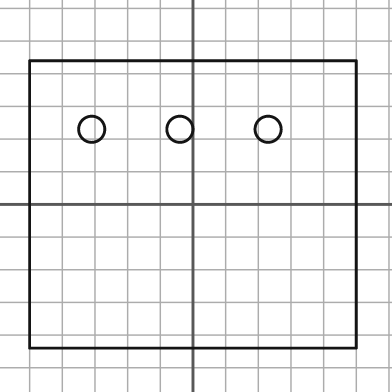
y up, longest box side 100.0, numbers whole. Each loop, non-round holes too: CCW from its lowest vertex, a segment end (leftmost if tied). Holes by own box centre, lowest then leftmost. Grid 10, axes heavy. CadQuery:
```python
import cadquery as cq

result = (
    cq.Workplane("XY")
    .moveTo(-50.0, -44.0)
    .lineTo(50.0, -44.0)
    .lineTo(50.0, 44.0)
    .lineTo(-50.0, 44.0)
    .close()
    .moveTo(-31.0, 23.0)
    .circle(4.0)
    .moveTo(-4.0, 23.0)
    .circle(4.0)
    .moveTo(23.0, 23.0)
    .circle(4.0)
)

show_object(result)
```